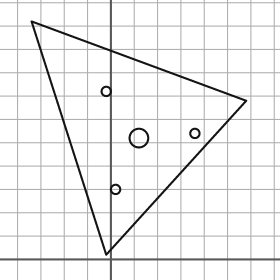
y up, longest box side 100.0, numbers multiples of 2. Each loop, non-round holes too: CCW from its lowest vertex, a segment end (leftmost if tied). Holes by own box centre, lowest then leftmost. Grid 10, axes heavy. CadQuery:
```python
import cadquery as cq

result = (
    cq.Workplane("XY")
    .moveTo(-2.0, 2.0)
    .lineTo(58.0, 68.0)
    .lineTo(-34.0, 102.0)
    .close()
    .moveTo(2.0, 30.0)
    .circle(2.0)
    .moveTo(12.0, 52.0)
    .circle(4.0)
    .moveTo(36.0, 54.0)
    .circle(2.0)
    .moveTo(-2.0, 72.0)
    .circle(2.0)
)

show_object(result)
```